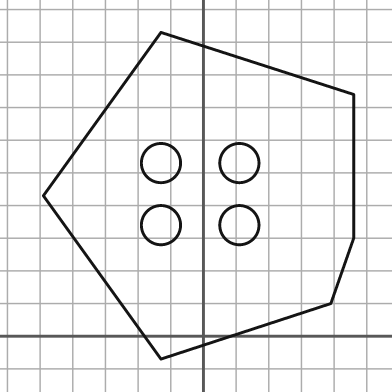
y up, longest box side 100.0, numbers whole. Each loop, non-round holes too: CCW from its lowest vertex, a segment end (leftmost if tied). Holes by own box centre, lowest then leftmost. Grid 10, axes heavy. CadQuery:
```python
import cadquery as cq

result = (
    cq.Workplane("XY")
    .moveTo(-13.0, -7.0)
    .lineTo(39.0, 10.0)
    .lineTo(46.0, 30.0)
    .lineTo(46.0, 74.0)
    .lineTo(-13.0, 93.0)
    .lineTo(-49.0, 43.0)
    .close()
    .moveTo(-13.0, 34.0)
    .circle(6.0)
    .moveTo(11.0, 34.0)
    .circle(6.0)
    .moveTo(-13.0, 53.0)
    .circle(6.0)
    .moveTo(11.0, 53.0)
    .circle(6.0)
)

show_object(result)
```